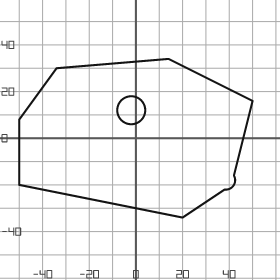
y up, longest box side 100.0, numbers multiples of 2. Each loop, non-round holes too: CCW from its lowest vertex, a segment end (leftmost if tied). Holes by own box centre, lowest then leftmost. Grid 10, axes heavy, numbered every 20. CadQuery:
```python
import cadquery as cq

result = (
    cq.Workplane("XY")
    .moveTo(20.0, -34.0)
    .lineTo(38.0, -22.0)
    .threePointArc((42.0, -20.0), (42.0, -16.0))
    .lineTo(50.0, 16.0)
    .lineTo(14.0, 34.0)
    .lineTo(-34.0, 30.0)
    .lineTo(-50.0, 8.0)
    .lineTo(-50.0, -20.0)
    .close()
    .moveTo(-2.0, 12.0)
    .circle(6.0)
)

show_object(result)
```